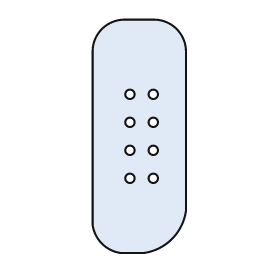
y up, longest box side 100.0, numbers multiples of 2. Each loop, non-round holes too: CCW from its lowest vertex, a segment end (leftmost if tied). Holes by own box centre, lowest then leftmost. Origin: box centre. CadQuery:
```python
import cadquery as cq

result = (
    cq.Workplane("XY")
    .moveTo(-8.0, -50.0)
    .lineTo(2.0, -50.0)
    .threePointArc((14.0, -44.0), (20.0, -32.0))
    .lineTo(20.0, 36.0)
    .threePointArc((16.0, 46.0), (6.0, 50.0))
    .lineTo(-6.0, 50.0)
    .threePointArc((-16.0, 46.0), (-20.0, 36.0))
    .lineTo(-20.0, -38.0)
    .threePointArc((-16.0, -46.0), (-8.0, -50.0))
    .close()
    .moveTo(-4.0, -18.0)
    .circle(2.0)
    .moveTo(6.0, -18.0)
    .circle(2.0)
    .moveTo(-4.0, -6.0)
    .circle(2.0)
    .moveTo(6.0, -6.0)
    .circle(2.0)
    .moveTo(-4.0, 6.0)
    .circle(2.0)
    .moveTo(6.0, 6.0)
    .circle(2.0)
    .moveTo(-4.0, 18.0)
    .circle(2.0)
    .moveTo(6.0, 18.0)
    .circle(2.0)
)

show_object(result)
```